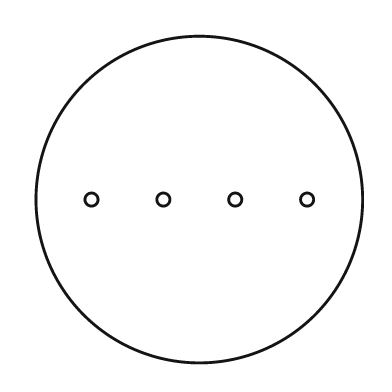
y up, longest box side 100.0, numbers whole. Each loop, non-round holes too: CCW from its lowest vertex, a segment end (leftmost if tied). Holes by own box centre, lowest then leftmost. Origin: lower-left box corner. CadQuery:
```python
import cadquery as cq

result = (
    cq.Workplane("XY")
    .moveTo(50.0, 50.0)
    .circle(50.0)
    .moveTo(17.0, 50.0)
    .circle(2.0)
    .moveTo(39.0, 50.0)
    .circle(2.0)
    .moveTo(61.0, 50.0)
    .circle(2.0)
    .moveTo(83.0, 50.0)
    .circle(2.0)
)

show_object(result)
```